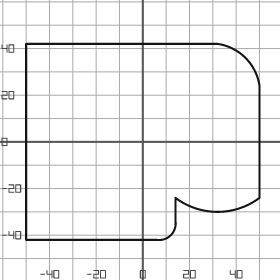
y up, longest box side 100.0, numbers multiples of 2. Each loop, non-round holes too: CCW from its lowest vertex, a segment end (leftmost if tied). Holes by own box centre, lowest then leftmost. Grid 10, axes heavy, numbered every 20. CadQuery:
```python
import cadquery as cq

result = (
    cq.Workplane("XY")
    .moveTo(-50.0, -42.0)
    .lineTo(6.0, -42.0)
    .threePointArc((12.0, -40.0), (14.0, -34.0))
    .lineTo(14.0, -24.0)
    .threePointArc((32.0, -30.0), (50.0, -24.0))
    .lineTo(50.0, 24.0)
    .threePointArc((44.0, 36.0), (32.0, 42.0))
    .lineTo(-50.0, 42.0)
    .close()
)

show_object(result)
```